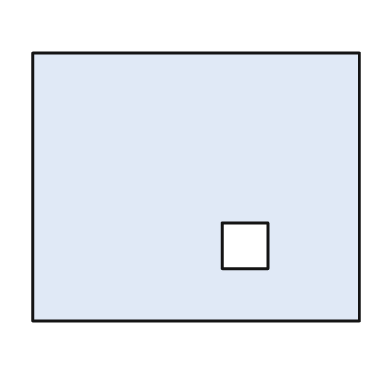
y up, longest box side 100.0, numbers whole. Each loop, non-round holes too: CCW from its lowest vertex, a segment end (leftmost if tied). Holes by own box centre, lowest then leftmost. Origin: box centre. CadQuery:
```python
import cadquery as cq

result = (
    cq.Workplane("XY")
    .moveTo(-50.0, -41.0)
    .lineTo(50.0, -41.0)
    .lineTo(50.0, 41.0)
    .lineTo(-50.0, 41.0)
    .close()
    .moveTo(8.0, -25.0)
    .lineTo(22.0, -25.0)
    .lineTo(22.0, -11.0)
    .lineTo(8.0, -11.0)
    .close()
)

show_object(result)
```